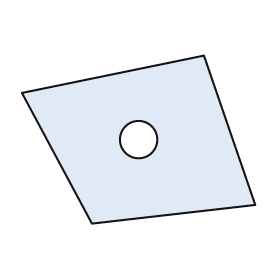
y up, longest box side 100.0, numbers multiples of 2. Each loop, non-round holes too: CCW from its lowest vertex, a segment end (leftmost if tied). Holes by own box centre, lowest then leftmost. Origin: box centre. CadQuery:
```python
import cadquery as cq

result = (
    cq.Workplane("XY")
    .moveTo(-20.0, -36.0)
    .lineTo(50.0, -28.0)
    .lineTo(28.0, 36.0)
    .lineTo(-50.0, 20.0)
    .close()
    .moveTo(0.0, 0.0)
    .circle(8.0)
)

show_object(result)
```